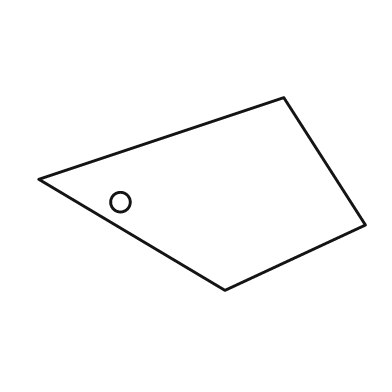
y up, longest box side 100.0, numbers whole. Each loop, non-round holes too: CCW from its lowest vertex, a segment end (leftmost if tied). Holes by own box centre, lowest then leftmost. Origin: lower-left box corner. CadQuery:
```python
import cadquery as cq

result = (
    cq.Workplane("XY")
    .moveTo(57.0, 0.0)
    .lineTo(100.0, 20.0)
    .lineTo(75.0, 59.0)
    .lineTo(0.0, 34.0)
    .close()
    .moveTo(25.0, 27.0)
    .circle(3.0)
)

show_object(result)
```